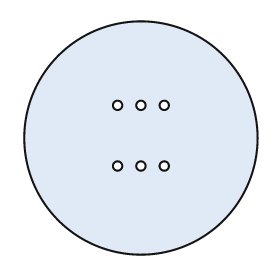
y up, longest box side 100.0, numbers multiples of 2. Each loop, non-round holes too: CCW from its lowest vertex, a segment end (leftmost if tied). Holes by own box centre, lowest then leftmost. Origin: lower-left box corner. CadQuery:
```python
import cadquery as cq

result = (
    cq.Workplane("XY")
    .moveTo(50.0, 50.0)
    .circle(50.0)
    .moveTo(40.0, 38.0)
    .circle(2.0)
    .moveTo(50.0, 38.0)
    .circle(2.0)
    .moveTo(60.0, 38.0)
    .circle(2.0)
    .moveTo(40.0, 64.0)
    .circle(2.0)
    .moveTo(50.0, 64.0)
    .circle(2.0)
    .moveTo(60.0, 64.0)
    .circle(2.0)
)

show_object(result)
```